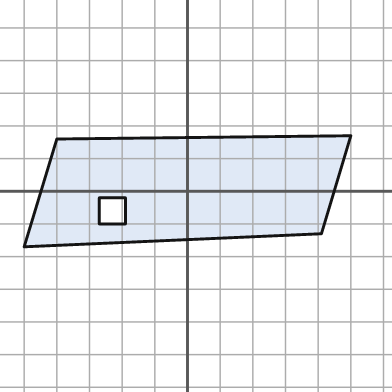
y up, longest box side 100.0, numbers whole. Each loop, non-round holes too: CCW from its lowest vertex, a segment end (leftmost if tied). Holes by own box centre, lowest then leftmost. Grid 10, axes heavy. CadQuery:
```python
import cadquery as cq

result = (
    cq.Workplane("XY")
    .moveTo(-50.0, -17.0)
    .lineTo(41.0, -13.0)
    .lineTo(50.0, 17.0)
    .lineTo(-40.0, 16.0)
    .close()
    .moveTo(-27.0, -10.0)
    .lineTo(-19.0, -10.0)
    .lineTo(-19.0, -2.0)
    .lineTo(-27.0, -2.0)
    .close()
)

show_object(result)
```